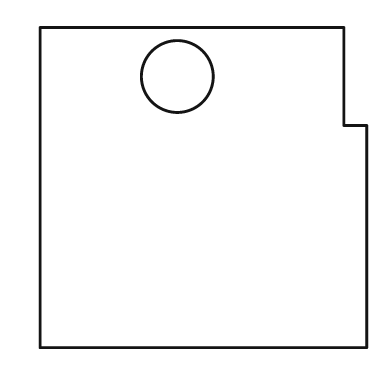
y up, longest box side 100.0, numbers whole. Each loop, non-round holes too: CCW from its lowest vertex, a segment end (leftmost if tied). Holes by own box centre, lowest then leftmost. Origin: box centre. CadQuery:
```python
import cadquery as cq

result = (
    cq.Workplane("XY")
    .moveTo(-50.0, -49.0)
    .lineTo(50.0, -49.0)
    .lineTo(50.0, 19.0)
    .lineTo(43.0, 19.0)
    .lineTo(43.0, 49.0)
    .lineTo(-50.0, 49.0)
    .close()
    .moveTo(-8.0, 34.0)
    .circle(11.0)
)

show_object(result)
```